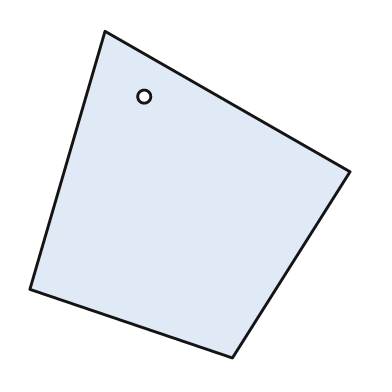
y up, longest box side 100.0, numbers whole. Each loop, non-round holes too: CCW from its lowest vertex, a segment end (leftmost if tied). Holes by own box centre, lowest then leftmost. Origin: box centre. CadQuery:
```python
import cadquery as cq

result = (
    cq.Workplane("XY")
    .moveTo(13.0, -50.0)
    .lineTo(49.0, 7.0)
    .lineTo(-26.0, 50.0)
    .lineTo(-49.0, -29.0)
    .close()
    .moveTo(-14.0, 30.0)
    .circle(2.0)
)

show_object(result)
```